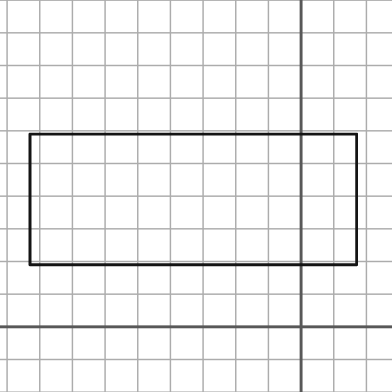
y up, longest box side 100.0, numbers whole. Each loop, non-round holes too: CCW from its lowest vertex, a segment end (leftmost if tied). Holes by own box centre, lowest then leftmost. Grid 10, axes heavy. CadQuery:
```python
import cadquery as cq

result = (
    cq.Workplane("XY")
    .moveTo(-83.0, 19.0)
    .lineTo(17.0, 19.0)
    .lineTo(17.0, 59.0)
    .lineTo(-83.0, 59.0)
    .close()
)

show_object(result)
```